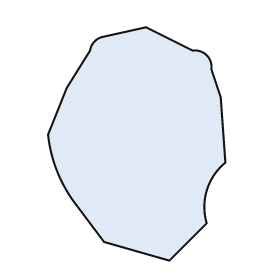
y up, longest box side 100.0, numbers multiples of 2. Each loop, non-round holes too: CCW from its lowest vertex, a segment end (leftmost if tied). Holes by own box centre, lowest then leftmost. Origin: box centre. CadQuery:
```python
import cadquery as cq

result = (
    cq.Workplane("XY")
    .moveTo(14.0, -50.0)
    .lineTo(30.0, -34.0)
    .threePointArc((30.0, -20.0), (38.0, -8.0))
    .lineTo(36.0, 20.0)
    .lineTo(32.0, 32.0)
    .threePointArc((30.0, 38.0), (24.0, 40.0))
    .lineTo(4.0, 50.0)
    .lineTo(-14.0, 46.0)
    .threePointArc((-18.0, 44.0), (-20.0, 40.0))
    .lineTo(-30.0, 24.0)
    .lineTo(-38.0, 4.0)
    .threePointArc((-34.0, -12.0), (-26.0, -26.0))
    .lineTo(-14.0, -42.0)
    .close()
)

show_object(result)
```